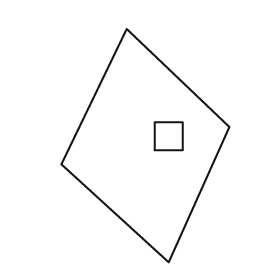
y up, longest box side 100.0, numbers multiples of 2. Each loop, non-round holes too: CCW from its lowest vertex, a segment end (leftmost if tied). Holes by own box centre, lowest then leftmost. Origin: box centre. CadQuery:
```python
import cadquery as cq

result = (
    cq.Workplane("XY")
    .moveTo(10.0, -50.0)
    .lineTo(36.0, 8.0)
    .lineTo(-8.0, 50.0)
    .lineTo(-36.0, -8.0)
    .close()
    .moveTo(4.0, -2.0)
    .lineTo(16.0, -2.0)
    .lineTo(16.0, 10.0)
    .lineTo(4.0, 10.0)
    .close()
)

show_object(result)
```